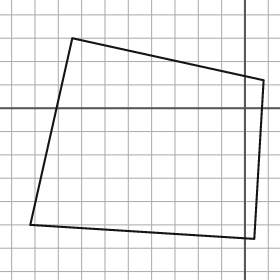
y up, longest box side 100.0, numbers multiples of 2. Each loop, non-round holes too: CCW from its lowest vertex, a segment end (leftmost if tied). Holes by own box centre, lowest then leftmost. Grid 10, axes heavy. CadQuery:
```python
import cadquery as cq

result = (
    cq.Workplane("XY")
    .moveTo(4.0, -56.0)
    .lineTo(8.0, 12.0)
    .lineTo(-74.0, 30.0)
    .lineTo(-92.0, -50.0)
    .close()
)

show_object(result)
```